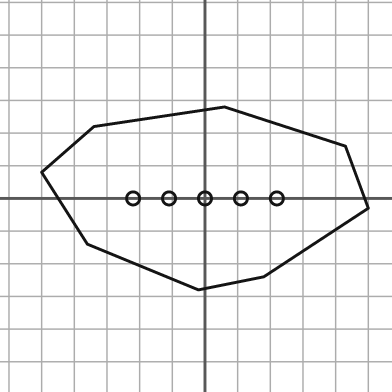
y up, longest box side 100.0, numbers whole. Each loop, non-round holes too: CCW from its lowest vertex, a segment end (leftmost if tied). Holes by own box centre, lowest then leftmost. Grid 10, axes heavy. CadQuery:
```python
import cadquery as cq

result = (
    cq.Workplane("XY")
    .moveTo(-2.0, -28.0)
    .lineTo(18.0, -24.0)
    .lineTo(50.0, -3.0)
    .lineTo(43.0, 16.0)
    .lineTo(6.0, 28.0)
    .lineTo(-34.0, 22.0)
    .lineTo(-50.0, 8.0)
    .lineTo(-36.0, -14.0)
    .close()
    .moveTo(-22.0, 0.0)
    .circle(2.0)
    .moveTo(-11.0, 0.0)
    .circle(2.0)
    .moveTo(0.0, 0.0)
    .circle(2.0)
    .moveTo(11.0, 0.0)
    .circle(2.0)
    .moveTo(22.0, 0.0)
    .circle(2.0)
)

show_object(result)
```